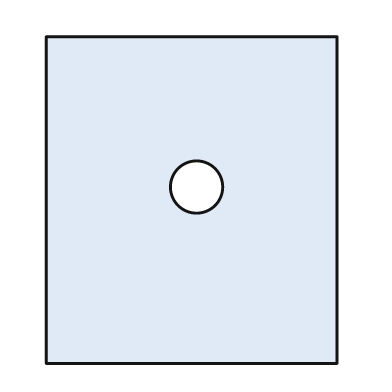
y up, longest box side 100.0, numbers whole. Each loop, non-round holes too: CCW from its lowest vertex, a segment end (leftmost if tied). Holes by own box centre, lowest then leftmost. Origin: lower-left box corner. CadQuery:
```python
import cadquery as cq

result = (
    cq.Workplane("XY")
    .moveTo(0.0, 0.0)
    .lineTo(89.0, 0.0)
    .lineTo(89.0, 100.0)
    .lineTo(0.0, 100.0)
    .close()
    .moveTo(46.0, 54.0)
    .circle(8.0)
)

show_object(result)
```